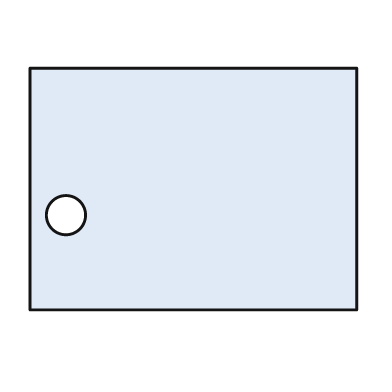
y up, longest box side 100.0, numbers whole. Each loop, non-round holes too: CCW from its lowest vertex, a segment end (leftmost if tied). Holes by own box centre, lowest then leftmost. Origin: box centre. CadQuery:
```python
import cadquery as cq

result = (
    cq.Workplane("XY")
    .moveTo(-50.0, -37.0)
    .lineTo(50.0, -37.0)
    .lineTo(50.0, 37.0)
    .lineTo(-50.0, 37.0)
    .close()
    .moveTo(-39.0, -8.0)
    .circle(6.0)
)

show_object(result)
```